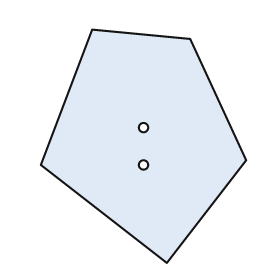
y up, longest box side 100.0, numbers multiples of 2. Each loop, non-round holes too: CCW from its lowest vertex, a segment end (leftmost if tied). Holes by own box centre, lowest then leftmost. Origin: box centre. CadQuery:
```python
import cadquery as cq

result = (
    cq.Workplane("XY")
    .moveTo(10.0, -50.0)
    .lineTo(44.0, -6.0)
    .lineTo(20.0, 46.0)
    .lineTo(-22.0, 50.0)
    .lineTo(-44.0, -8.0)
    .close()
    .moveTo(0.0, -8.0)
    .circle(2.0)
    .moveTo(0.0, 8.0)
    .circle(2.0)
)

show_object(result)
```